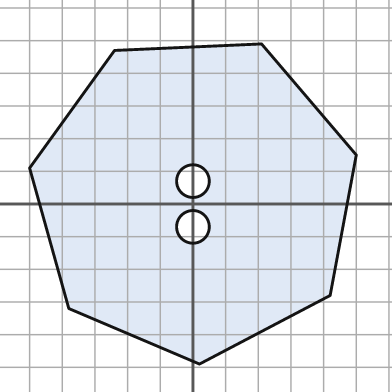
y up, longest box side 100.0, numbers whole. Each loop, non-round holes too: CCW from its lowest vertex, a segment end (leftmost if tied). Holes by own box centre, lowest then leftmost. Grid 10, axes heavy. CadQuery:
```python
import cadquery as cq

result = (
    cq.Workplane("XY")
    .moveTo(2.0, -49.0)
    .lineTo(42.0, -28.0)
    .lineTo(50.0, 15.0)
    .lineTo(21.0, 49.0)
    .lineTo(-24.0, 47.0)
    .lineTo(-50.0, 11.0)
    .lineTo(-38.0, -32.0)
    .close()
    .moveTo(0.0, -7.0)
    .circle(5.0)
    .moveTo(0.0, 7.0)
    .circle(5.0)
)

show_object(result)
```